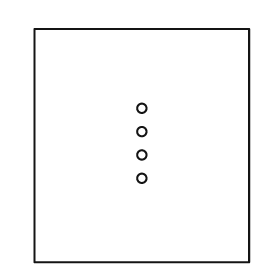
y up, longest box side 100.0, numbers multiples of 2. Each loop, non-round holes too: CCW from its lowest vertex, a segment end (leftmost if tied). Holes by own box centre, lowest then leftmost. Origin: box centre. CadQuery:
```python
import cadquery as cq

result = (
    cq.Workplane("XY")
    .moveTo(-46.0, -50.0)
    .lineTo(46.0, -50.0)
    .lineTo(46.0, 50.0)
    .lineTo(-46.0, 50.0)
    .close()
    .moveTo(0.0, -14.0)
    .circle(2.0)
    .moveTo(0.0, -4.0)
    .circle(2.0)
    .moveTo(0.0, 6.0)
    .circle(2.0)
    .moveTo(0.0, 16.0)
    .circle(2.0)
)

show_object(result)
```